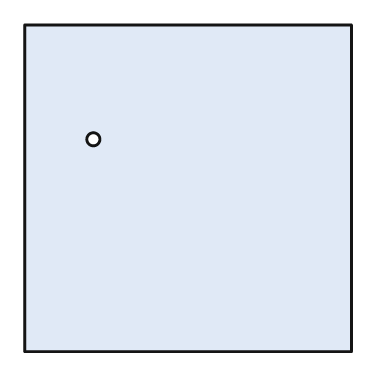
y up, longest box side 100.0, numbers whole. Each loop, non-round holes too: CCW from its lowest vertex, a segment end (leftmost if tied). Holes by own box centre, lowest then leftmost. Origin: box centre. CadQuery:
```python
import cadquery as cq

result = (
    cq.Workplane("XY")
    .moveTo(-50.0, -50.0)
    .lineTo(50.0, -50.0)
    .lineTo(50.0, 50.0)
    .lineTo(-50.0, 50.0)
    .close()
    .moveTo(-29.0, 15.0)
    .circle(2.0)
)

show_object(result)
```